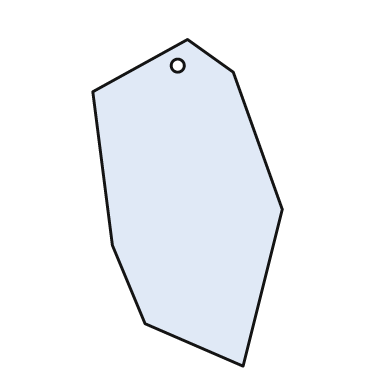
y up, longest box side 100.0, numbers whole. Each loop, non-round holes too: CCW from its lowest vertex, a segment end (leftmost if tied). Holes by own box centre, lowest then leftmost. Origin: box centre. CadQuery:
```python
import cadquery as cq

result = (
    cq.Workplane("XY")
    .moveTo(17.0, -50.0)
    .lineTo(29.0, -2.0)
    .lineTo(14.0, 40.0)
    .lineTo(0.0, 50.0)
    .lineTo(-29.0, 34.0)
    .lineTo(-23.0, -13.0)
    .lineTo(-13.0, -37.0)
    .close()
    .moveTo(-3.0, 42.0)
    .circle(2.0)
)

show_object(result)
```